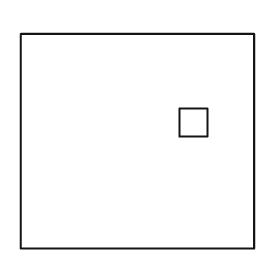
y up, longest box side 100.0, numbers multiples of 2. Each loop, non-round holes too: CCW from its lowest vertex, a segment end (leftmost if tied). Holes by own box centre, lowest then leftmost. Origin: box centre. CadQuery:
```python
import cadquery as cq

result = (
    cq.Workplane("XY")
    .moveTo(-50.0, -46.0)
    .lineTo(50.0, -46.0)
    .lineTo(50.0, 46.0)
    .lineTo(-50.0, 46.0)
    .close()
    .moveTo(18.0, 2.0)
    .lineTo(30.0, 2.0)
    .lineTo(30.0, 14.0)
    .lineTo(18.0, 14.0)
    .close()
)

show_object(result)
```